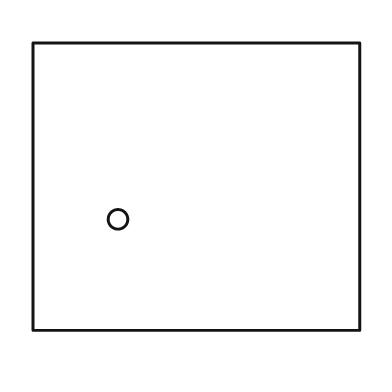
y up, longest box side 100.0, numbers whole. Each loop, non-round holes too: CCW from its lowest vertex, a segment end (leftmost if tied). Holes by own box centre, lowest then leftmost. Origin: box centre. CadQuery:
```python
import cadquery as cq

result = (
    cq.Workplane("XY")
    .moveTo(-50.0, -44.0)
    .lineTo(50.0, -44.0)
    .lineTo(50.0, 44.0)
    .lineTo(-50.0, 44.0)
    .close()
    .moveTo(-24.0, -10.0)
    .circle(3.0)
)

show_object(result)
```